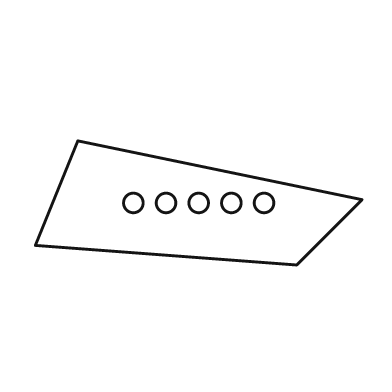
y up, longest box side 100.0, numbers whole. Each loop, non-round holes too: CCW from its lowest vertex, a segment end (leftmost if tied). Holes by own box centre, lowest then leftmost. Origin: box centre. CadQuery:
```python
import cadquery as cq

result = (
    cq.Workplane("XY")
    .moveTo(30.0, -19.0)
    .lineTo(50.0, 1.0)
    .lineTo(-37.0, 19.0)
    .lineTo(-50.0, -13.0)
    .close()
    .moveTo(-20.0, 0.0)
    .circle(3.0)
    .moveTo(-10.0, 0.0)
    .circle(3.0)
    .moveTo(0.0, 0.0)
    .circle(3.0)
    .moveTo(10.0, 0.0)
    .circle(3.0)
    .moveTo(20.0, 0.0)
    .circle(3.0)
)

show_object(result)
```